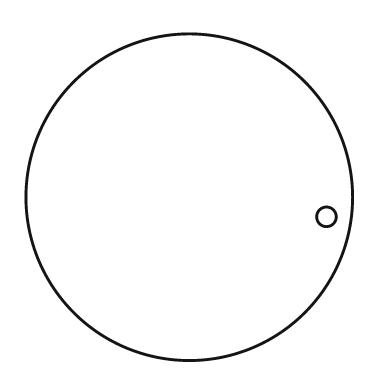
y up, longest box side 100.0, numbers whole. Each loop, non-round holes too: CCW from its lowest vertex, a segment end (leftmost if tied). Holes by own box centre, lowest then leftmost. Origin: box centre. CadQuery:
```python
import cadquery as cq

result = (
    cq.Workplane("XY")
    .moveTo(0.0, 0.0)
    .circle(50.0)
    .moveTo(42.0, -6.0)
    .circle(3.0)
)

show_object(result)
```